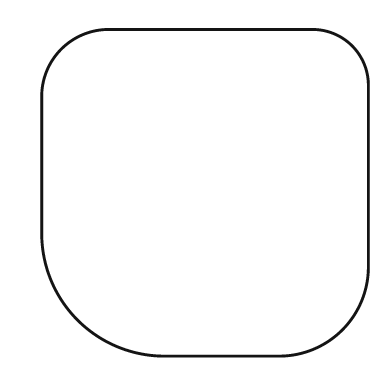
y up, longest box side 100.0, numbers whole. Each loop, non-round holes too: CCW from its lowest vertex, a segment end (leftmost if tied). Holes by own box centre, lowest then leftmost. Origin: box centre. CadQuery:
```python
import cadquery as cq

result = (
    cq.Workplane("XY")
    .moveTo(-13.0, -50.0)
    .lineTo(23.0, -50.0)
    .threePointArc((42.0, -42.0), (50.0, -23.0))
    .lineTo(50.0, 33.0)
    .threePointArc((45.0, 45.0), (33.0, 50.0))
    .lineTo(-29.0, 50.0)
    .threePointArc((-44.0, 44.0), (-50.0, 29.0))
    .lineTo(-50.0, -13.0)
    .threePointArc((-39.0, -39.0), (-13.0, -50.0))
    .close()
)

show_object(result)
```